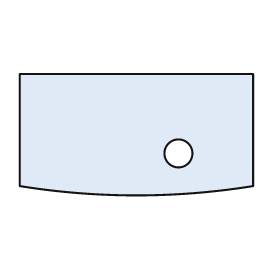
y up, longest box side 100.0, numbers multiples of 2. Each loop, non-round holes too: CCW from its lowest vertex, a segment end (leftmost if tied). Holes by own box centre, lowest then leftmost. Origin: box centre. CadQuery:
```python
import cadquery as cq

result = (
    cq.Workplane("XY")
    .moveTo(-50.0, -22.0)
    .threePointArc((0.0, -26.0), (50.0, -22.0))
    .lineTo(50.0, 26.0)
    .lineTo(-50.0, 26.0)
    .close()
    .moveTo(18.0, -8.0)
    .circle(6.0)
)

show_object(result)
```